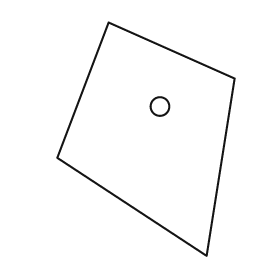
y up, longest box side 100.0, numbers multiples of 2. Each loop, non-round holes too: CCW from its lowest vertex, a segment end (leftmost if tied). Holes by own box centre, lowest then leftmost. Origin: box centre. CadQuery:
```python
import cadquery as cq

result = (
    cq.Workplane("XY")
    .moveTo(26.0, -50.0)
    .lineTo(38.0, 26.0)
    .lineTo(-16.0, 50.0)
    .lineTo(-38.0, -8.0)
    .close()
    .moveTo(6.0, 14.0)
    .circle(4.0)
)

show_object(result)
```